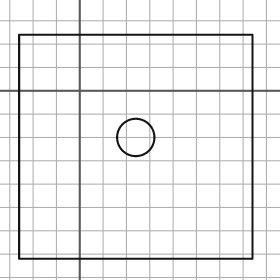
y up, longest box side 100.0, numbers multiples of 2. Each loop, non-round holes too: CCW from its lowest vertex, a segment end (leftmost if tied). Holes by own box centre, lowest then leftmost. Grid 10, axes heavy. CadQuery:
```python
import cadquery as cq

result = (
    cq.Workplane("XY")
    .moveTo(-26.0, -72.0)
    .lineTo(74.0, -72.0)
    .lineTo(74.0, 24.0)
    .lineTo(-26.0, 24.0)
    .close()
    .moveTo(24.0, -20.0)
    .circle(8.0)
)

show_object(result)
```